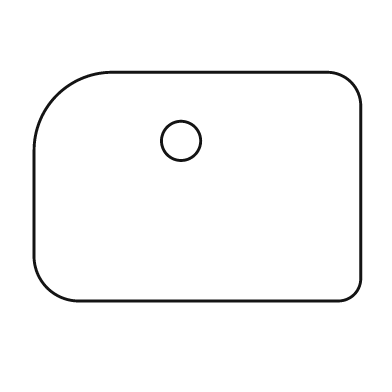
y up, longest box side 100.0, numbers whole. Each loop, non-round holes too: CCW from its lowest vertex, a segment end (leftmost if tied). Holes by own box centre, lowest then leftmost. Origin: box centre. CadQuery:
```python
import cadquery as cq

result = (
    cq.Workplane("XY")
    .moveTo(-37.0, -35.0)
    .lineTo(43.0, -35.0)
    .threePointArc((48.0, -33.0), (50.0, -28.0))
    .lineTo(50.0, 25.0)
    .threePointArc((47.0, 32.0), (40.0, 35.0))
    .lineTo(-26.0, 35.0)
    .threePointArc((-43.0, 28.0), (-50.0, 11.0))
    .lineTo(-50.0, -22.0)
    .threePointArc((-46.0, -31.0), (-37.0, -35.0))
    .close()
    .moveTo(-5.0, 14.0)
    .circle(6.0)
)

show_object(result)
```